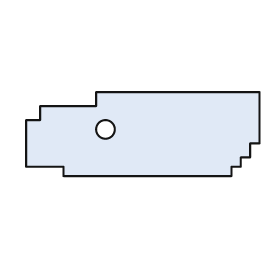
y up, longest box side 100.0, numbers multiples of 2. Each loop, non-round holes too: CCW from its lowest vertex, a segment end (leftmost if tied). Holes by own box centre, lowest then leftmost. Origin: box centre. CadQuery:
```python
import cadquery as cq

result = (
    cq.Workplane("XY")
    .moveTo(-34.0, -18.0)
    .lineTo(38.0, -18.0)
    .lineTo(38.0, -14.0)
    .lineTo(42.0, -14.0)
    .lineTo(42.0, -10.0)
    .lineTo(46.0, -10.0)
    .lineTo(46.0, -4.0)
    .lineTo(50.0, -4.0)
    .lineTo(50.0, 18.0)
    .lineTo(-20.0, 18.0)
    .lineTo(-20.0, 12.0)
    .lineTo(-44.0, 12.0)
    .lineTo(-44.0, 6.0)
    .lineTo(-50.0, 6.0)
    .lineTo(-50.0, -14.0)
    .lineTo(-34.0, -14.0)
    .close()
    .moveTo(-16.0, 2.0)
    .circle(4.0)
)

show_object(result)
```